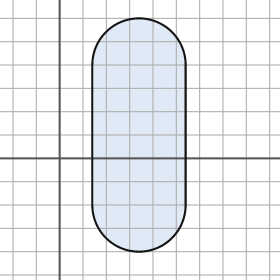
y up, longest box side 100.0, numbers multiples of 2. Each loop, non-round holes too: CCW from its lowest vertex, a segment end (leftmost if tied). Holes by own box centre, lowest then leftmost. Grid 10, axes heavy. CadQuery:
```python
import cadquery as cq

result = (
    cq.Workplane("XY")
    .moveTo(14.0, -20.0)
    .threePointArc((34.0, -40.0), (54.0, -20.0))
    .lineTo(54.0, 40.0)
    .threePointArc((34.0, 60.0), (14.0, 40.0))
    .close()
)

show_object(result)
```